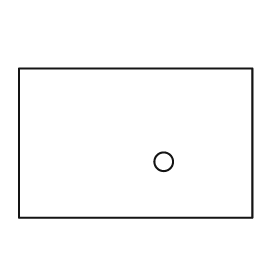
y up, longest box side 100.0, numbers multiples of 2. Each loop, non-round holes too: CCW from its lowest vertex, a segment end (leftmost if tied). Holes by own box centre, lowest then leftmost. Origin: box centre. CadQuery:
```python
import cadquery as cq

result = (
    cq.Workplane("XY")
    .moveTo(-50.0, -32.0)
    .lineTo(50.0, -32.0)
    .lineTo(50.0, 32.0)
    .lineTo(-50.0, 32.0)
    .close()
    .moveTo(12.0, -8.0)
    .circle(4.0)
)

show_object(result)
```